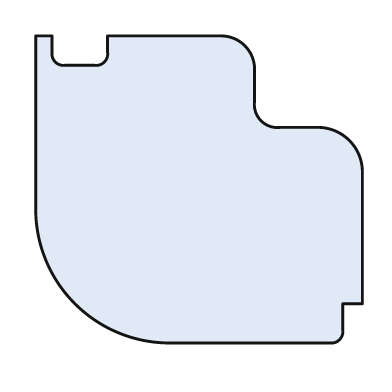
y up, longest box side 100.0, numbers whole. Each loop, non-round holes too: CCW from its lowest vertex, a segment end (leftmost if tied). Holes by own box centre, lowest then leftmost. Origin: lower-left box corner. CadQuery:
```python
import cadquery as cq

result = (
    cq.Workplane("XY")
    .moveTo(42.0, 0.0)
    .lineTo(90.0, 0.0)
    .threePointArc((93.0, 1.0), (94.0, 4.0))
    .lineTo(94.0, 12.0)
    .lineTo(100.0, 12.0)
    .lineTo(100.0, 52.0)
    .threePointArc((96.0, 62.0), (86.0, 66.0))
    .lineTo(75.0, 66.0)
    .threePointArc((69.0, 68.0), (67.0, 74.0))
    .lineTo(67.0, 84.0)
    .threePointArc((64.0, 91.0), (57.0, 94.0))
    .lineTo(22.0, 94.0)
    .lineTo(22.0, 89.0)
    .threePointArc((21.0, 86.0), (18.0, 85.0))
    .lineTo(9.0, 85.0)
    .threePointArc((6.0, 86.0), (5.0, 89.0))
    .lineTo(5.0, 94.0)
    .lineTo(0.0, 94.0)
    .lineTo(0.0, 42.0)
    .threePointArc((12.0, 12.0), (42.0, 0.0))
    .close()
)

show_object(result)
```